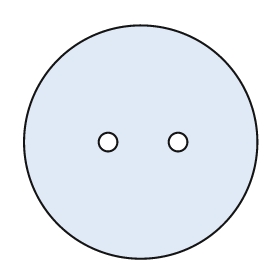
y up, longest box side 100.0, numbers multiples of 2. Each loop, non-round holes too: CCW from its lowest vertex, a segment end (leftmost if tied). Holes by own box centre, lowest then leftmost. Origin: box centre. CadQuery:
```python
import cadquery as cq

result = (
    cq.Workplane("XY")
    .moveTo(0.0, 0.0)
    .circle(50.0)
    .moveTo(-14.0, 0.0)
    .circle(4.0)
    .moveTo(16.0, 0.0)
    .circle(4.0)
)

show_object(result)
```